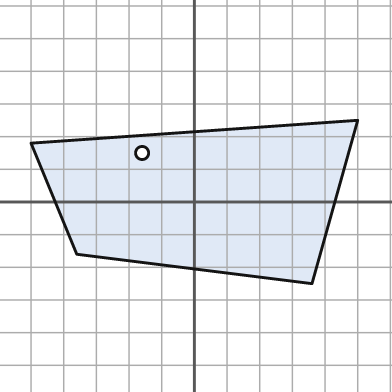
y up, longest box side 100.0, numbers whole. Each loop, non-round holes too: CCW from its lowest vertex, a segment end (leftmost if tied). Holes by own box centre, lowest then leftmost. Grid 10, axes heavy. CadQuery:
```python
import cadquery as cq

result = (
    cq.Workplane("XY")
    .moveTo(36.0, -25.0)
    .lineTo(50.0, 25.0)
    .lineTo(-50.0, 18.0)
    .lineTo(-36.0, -16.0)
    .close()
    .moveTo(-16.0, 15.0)
    .circle(2.0)
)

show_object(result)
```